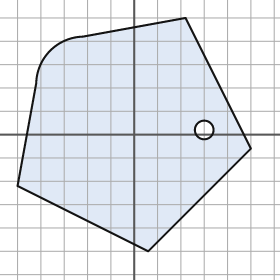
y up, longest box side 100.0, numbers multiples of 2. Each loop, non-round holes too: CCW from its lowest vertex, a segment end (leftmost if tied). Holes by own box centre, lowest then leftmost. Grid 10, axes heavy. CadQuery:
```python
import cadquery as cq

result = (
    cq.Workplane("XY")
    .moveTo(6.0, -50.0)
    .lineTo(50.0, -6.0)
    .lineTo(22.0, 50.0)
    .lineTo(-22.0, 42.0)
    .threePointArc((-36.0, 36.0), (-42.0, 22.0))
    .lineTo(-50.0, -22.0)
    .close()
    .moveTo(30.0, 2.0)
    .circle(4.0)
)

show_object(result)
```